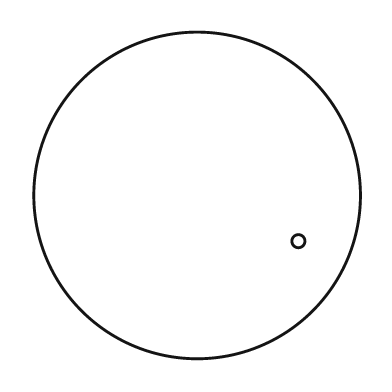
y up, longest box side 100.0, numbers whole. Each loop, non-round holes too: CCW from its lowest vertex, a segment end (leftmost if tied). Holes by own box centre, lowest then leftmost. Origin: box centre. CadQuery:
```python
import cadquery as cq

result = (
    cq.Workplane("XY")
    .moveTo(0.0, 0.0)
    .circle(50.0)
    .moveTo(31.0, -14.0)
    .circle(2.0)
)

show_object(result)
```